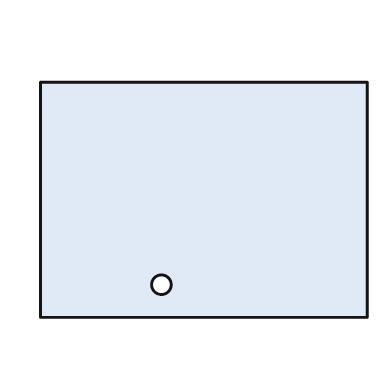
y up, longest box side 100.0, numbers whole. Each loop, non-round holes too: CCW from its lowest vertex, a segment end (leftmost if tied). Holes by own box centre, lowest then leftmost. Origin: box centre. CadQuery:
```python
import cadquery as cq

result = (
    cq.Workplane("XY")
    .moveTo(-50.0, -36.0)
    .lineTo(50.0, -36.0)
    .lineTo(50.0, 36.0)
    .lineTo(-50.0, 36.0)
    .close()
    .moveTo(-13.0, -26.0)
    .circle(3.0)
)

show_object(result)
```